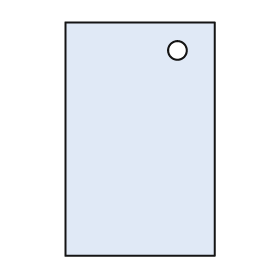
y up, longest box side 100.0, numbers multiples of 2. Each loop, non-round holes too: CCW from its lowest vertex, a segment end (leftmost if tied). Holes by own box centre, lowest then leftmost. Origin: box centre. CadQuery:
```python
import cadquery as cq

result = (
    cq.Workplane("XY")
    .moveTo(-32.0, -50.0)
    .lineTo(32.0, -50.0)
    .lineTo(32.0, 50.0)
    .lineTo(-32.0, 50.0)
    .close()
    .moveTo(16.0, 38.0)
    .circle(4.0)
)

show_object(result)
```